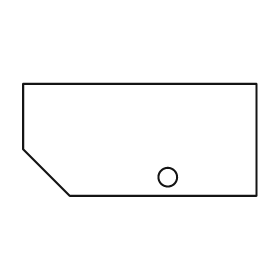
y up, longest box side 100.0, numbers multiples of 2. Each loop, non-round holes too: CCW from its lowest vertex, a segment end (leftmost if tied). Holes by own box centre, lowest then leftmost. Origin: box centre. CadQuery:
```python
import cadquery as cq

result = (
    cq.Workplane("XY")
    .moveTo(-30.0, -24.0)
    .lineTo(50.0, -24.0)
    .lineTo(50.0, 24.0)
    .lineTo(-50.0, 24.0)
    .lineTo(-50.0, -4.0)
    .close()
    .moveTo(12.0, -16.0)
    .circle(4.0)
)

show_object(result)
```